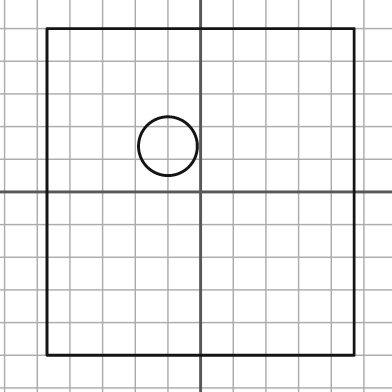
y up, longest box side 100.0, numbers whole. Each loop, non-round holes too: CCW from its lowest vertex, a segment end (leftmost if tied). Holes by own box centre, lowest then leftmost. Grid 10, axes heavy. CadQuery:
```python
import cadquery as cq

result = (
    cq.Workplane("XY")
    .moveTo(-47.0, -50.0)
    .lineTo(47.0, -50.0)
    .lineTo(47.0, 50.0)
    .lineTo(-47.0, 50.0)
    .close()
    .moveTo(-10.0, 14.0)
    .circle(9.0)
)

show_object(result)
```